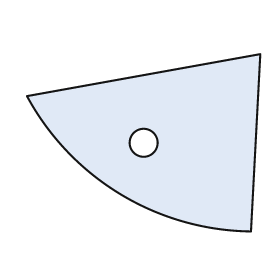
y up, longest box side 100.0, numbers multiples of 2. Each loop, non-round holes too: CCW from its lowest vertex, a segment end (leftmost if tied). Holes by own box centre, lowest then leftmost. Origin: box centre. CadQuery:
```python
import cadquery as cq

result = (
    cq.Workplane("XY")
    .moveTo(46.0, -38.0)
    .lineTo(50.0, 38.0)
    .lineTo(-50.0, 20.0)
    .threePointArc((-10.0, -22.0), (46.0, -38.0))
    .close()
    .moveTo(0.0, 0.0)
    .circle(6.0)
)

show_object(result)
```